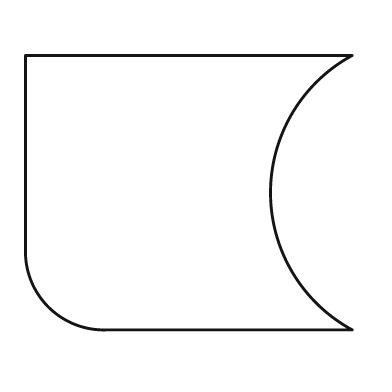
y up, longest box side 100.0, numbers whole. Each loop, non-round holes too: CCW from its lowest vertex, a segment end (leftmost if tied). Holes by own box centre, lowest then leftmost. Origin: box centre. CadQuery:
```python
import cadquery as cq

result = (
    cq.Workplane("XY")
    .moveTo(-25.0, -42.0)
    .lineTo(50.0, -42.0)
    .threePointArc((25.0, 0.0), (50.0, 42.0))
    .lineTo(-50.0, 42.0)
    .lineTo(-50.0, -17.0)
    .threePointArc((-43.0, -35.0), (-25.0, -42.0))
    .close()
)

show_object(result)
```